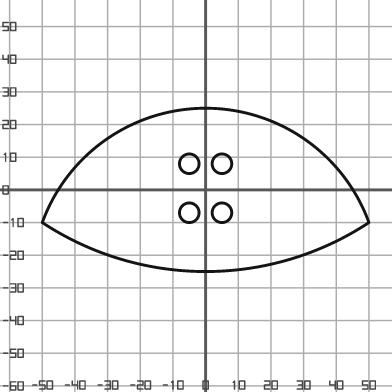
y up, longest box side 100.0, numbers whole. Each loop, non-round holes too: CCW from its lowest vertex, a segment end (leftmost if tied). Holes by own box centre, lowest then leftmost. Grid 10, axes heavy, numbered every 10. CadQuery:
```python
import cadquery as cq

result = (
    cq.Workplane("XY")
    .moveTo(-50.0, -10.0)
    .threePointArc((0.0, -25.0), (50.0, -10.0))
    .threePointArc((0.0, 25.0), (-50.0, -10.0))
    .close()
    .moveTo(-5.0, -7.0)
    .circle(3.0)
    .moveTo(5.0, -7.0)
    .circle(3.0)
    .moveTo(-5.0, 8.0)
    .circle(3.0)
    .moveTo(5.0, 8.0)
    .circle(3.0)
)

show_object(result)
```